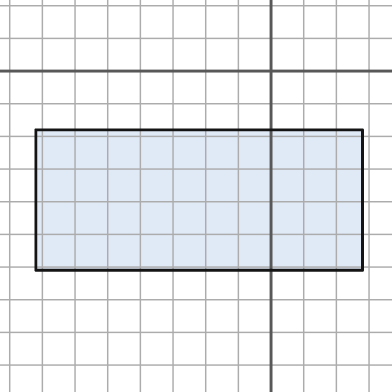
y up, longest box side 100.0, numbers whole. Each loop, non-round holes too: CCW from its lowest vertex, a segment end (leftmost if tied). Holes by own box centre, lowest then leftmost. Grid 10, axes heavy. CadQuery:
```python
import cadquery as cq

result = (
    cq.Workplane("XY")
    .moveTo(-72.0, -61.0)
    .lineTo(28.0, -61.0)
    .lineTo(28.0, -18.0)
    .lineTo(-72.0, -18.0)
    .close()
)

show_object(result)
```